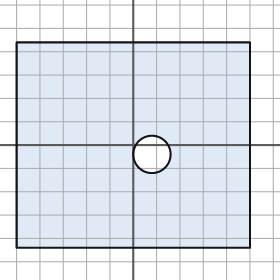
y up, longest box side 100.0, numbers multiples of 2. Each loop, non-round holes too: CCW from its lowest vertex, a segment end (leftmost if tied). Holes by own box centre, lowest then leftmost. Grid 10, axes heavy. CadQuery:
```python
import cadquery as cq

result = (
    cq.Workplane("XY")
    .moveTo(-50.0, -44.0)
    .lineTo(50.0, -44.0)
    .lineTo(50.0, 44.0)
    .lineTo(-50.0, 44.0)
    .close()
    .moveTo(8.0, -4.0)
    .circle(8.0)
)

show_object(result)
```